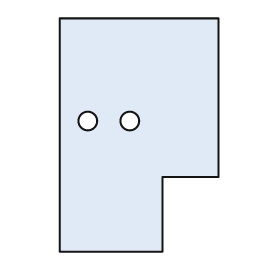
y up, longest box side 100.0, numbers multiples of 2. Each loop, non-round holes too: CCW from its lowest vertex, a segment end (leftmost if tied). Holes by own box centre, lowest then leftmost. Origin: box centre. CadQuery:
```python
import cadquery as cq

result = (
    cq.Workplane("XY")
    .moveTo(-34.0, -50.0)
    .lineTo(10.0, -50.0)
    .lineTo(10.0, -18.0)
    .lineTo(34.0, -18.0)
    .lineTo(34.0, 50.0)
    .lineTo(-34.0, 50.0)
    .close()
    .moveTo(-22.0, 6.0)
    .circle(4.0)
    .moveTo(-4.0, 6.0)
    .circle(4.0)
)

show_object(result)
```